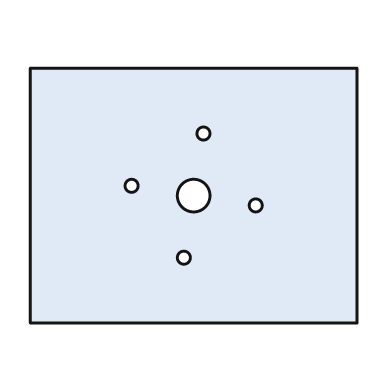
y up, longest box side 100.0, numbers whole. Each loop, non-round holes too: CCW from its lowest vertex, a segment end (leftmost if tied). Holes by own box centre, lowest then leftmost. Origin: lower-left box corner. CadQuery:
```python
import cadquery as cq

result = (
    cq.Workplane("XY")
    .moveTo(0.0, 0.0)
    .lineTo(100.0, 0.0)
    .lineTo(100.0, 78.0)
    .lineTo(0.0, 78.0)
    .close()
    .moveTo(47.0, 20.0)
    .circle(2.0)
    .moveTo(69.0, 36.0)
    .circle(2.0)
    .moveTo(50.0, 39.0)
    .circle(5.0)
    .moveTo(31.0, 42.0)
    .circle(2.0)
    .moveTo(53.0, 58.0)
    .circle(2.0)
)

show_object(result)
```